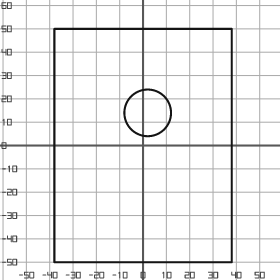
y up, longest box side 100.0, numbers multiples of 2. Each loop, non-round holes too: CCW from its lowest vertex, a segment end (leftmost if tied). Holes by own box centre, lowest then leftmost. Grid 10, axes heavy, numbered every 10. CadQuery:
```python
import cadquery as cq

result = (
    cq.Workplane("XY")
    .moveTo(-38.0, -50.0)
    .lineTo(38.0, -50.0)
    .lineTo(38.0, 50.0)
    .lineTo(-38.0, 50.0)
    .close()
    .moveTo(2.0, 14.0)
    .circle(10.0)
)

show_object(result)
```